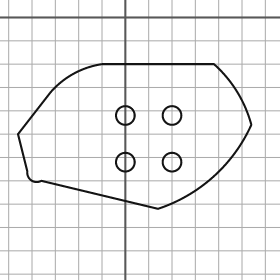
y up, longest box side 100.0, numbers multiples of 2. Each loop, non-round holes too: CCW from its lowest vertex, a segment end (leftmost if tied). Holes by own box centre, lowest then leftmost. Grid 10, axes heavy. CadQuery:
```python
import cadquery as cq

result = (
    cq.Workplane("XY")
    .moveTo(14.0, -82.0)
    .threePointArc((38.0, -68.0), (54.0, -46.0))
    .threePointArc((48.0, -32.0), (38.0, -20.0))
    .lineTo(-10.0, -20.0)
    .threePointArc((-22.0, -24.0), (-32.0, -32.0))
    .lineTo(-46.0, -50.0)
    .lineTo(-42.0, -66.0)
    .threePointArc((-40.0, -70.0), (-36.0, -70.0))
    .close()
    .moveTo(0.0, -62.0)
    .circle(4.0)
    .moveTo(20.0, -62.0)
    .circle(4.0)
    .moveTo(0.0, -42.0)
    .circle(4.0)
    .moveTo(20.0, -42.0)
    .circle(4.0)
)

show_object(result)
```